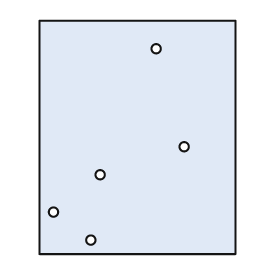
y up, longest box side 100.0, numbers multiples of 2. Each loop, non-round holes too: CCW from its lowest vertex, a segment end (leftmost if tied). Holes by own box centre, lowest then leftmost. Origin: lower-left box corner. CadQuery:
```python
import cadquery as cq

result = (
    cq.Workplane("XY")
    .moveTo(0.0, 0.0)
    .lineTo(84.0, 0.0)
    .lineTo(84.0, 100.0)
    .lineTo(0.0, 100.0)
    .close()
    .moveTo(22.0, 6.0)
    .circle(2.0)
    .moveTo(6.0, 18.0)
    .circle(2.0)
    .moveTo(26.0, 34.0)
    .circle(2.0)
    .moveTo(62.0, 46.0)
    .circle(2.0)
    .moveTo(50.0, 88.0)
    .circle(2.0)
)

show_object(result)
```